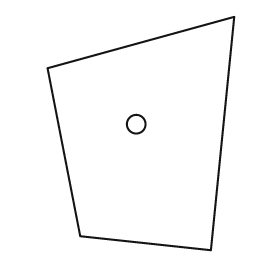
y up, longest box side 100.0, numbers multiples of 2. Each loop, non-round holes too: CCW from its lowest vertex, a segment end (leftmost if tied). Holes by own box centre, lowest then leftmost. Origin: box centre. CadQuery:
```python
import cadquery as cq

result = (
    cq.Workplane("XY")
    .moveTo(30.0, -50.0)
    .lineTo(40.0, 50.0)
    .lineTo(-40.0, 28.0)
    .lineTo(-26.0, -44.0)
    .close()
    .moveTo(-2.0, 4.0)
    .circle(4.0)
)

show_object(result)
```